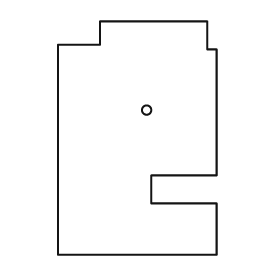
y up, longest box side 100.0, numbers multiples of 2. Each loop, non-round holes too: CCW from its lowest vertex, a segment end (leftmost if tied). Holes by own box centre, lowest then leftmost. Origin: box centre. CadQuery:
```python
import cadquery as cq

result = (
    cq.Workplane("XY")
    .moveTo(-34.0, -50.0)
    .lineTo(34.0, -50.0)
    .lineTo(34.0, -28.0)
    .lineTo(6.0, -28.0)
    .lineTo(6.0, -16.0)
    .lineTo(34.0, -16.0)
    .lineTo(34.0, 38.0)
    .lineTo(30.0, 38.0)
    .lineTo(30.0, 50.0)
    .lineTo(-16.0, 50.0)
    .lineTo(-16.0, 40.0)
    .lineTo(-34.0, 40.0)
    .close()
    .moveTo(4.0, 12.0)
    .circle(2.0)
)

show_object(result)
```